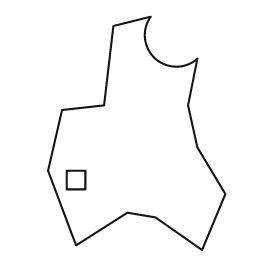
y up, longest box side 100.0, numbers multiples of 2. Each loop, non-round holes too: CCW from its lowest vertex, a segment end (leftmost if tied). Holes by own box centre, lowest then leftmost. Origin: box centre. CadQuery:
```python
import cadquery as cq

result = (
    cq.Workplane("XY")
    .moveTo(28.0, -50.0)
    .lineTo(38.0, -26.0)
    .lineTo(26.0, -6.0)
    .lineTo(22.0, 12.0)
    .lineTo(26.0, 32.0)
    .threePointArc((8.0, 32.0), (6.0, 50.0))
    .lineTo(-10.0, 46.0)
    .lineTo(-14.0, 12.0)
    .lineTo(-32.0, 10.0)
    .lineTo(-38.0, -16.0)
    .lineTo(-26.0, -48.0)
    .lineTo(-4.0, -34.0)
    .lineTo(8.0, -36.0)
    .close()
    .moveTo(-30.0, -24.0)
    .lineTo(-22.0, -24.0)
    .lineTo(-22.0, -16.0)
    .lineTo(-30.0, -16.0)
    .close()
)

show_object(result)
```